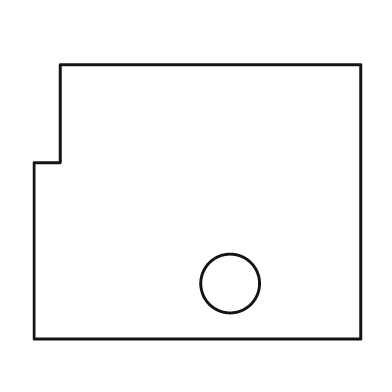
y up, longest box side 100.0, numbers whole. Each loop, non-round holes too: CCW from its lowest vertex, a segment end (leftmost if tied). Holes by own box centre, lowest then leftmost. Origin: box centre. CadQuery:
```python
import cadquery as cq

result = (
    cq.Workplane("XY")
    .moveTo(-50.0, -42.0)
    .lineTo(50.0, -42.0)
    .lineTo(50.0, 42.0)
    .lineTo(-42.0, 42.0)
    .lineTo(-42.0, 12.0)
    .lineTo(-50.0, 12.0)
    .close()
    .moveTo(10.0, -25.0)
    .circle(9.0)
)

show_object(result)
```